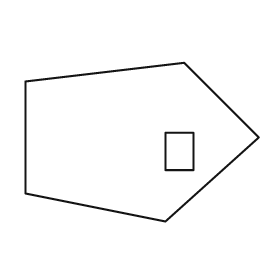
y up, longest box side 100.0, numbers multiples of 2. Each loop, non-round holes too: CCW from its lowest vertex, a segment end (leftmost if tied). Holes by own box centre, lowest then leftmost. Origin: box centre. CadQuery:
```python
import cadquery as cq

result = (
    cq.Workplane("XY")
    .moveTo(10.0, -34.0)
    .lineTo(50.0, 2.0)
    .lineTo(18.0, 34.0)
    .lineTo(-50.0, 26.0)
    .lineTo(-50.0, -22.0)
    .close()
    .moveTo(10.0, -12.0)
    .lineTo(22.0, -12.0)
    .lineTo(22.0, 4.0)
    .lineTo(10.0, 4.0)
    .close()
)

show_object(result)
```